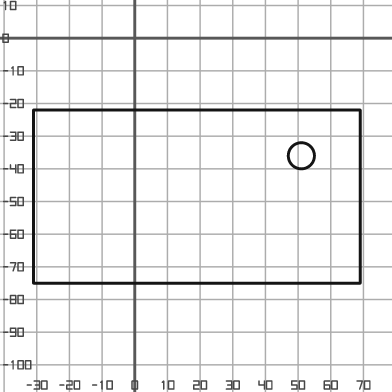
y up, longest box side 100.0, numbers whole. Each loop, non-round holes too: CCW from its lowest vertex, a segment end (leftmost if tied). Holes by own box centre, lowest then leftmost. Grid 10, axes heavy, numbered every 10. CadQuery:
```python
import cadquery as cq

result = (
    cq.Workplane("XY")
    .moveTo(-31.0, -75.0)
    .lineTo(69.0, -75.0)
    .lineTo(69.0, -22.0)
    .lineTo(-31.0, -22.0)
    .close()
    .moveTo(51.0, -36.0)
    .circle(4.0)
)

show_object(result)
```